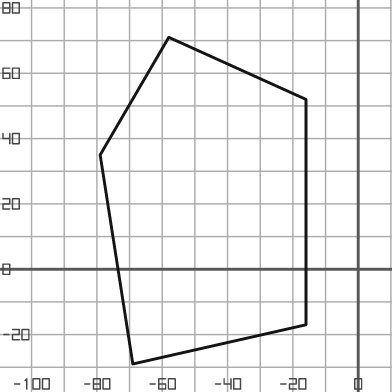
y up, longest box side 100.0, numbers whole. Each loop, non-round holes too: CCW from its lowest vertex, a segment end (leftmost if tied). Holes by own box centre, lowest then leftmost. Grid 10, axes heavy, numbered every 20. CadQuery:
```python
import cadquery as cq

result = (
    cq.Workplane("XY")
    .moveTo(-69.0, -29.0)
    .lineTo(-16.0, -17.0)
    .lineTo(-16.0, 52.0)
    .lineTo(-58.0, 71.0)
    .lineTo(-79.0, 35.0)
    .close()
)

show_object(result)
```